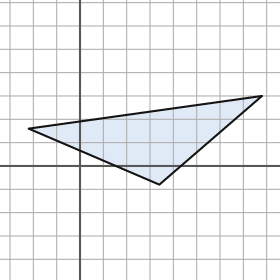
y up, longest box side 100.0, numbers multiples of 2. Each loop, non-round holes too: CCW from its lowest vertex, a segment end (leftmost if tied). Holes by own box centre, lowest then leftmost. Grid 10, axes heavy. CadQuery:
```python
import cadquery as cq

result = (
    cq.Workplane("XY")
    .moveTo(34.0, -8.0)
    .lineTo(78.0, 30.0)
    .lineTo(-22.0, 16.0)
    .close()
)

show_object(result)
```